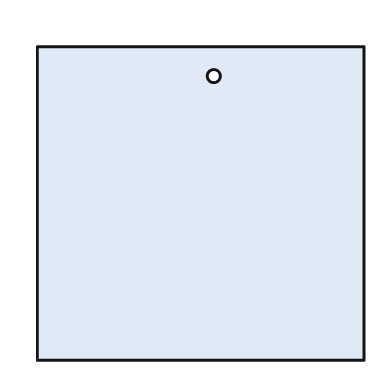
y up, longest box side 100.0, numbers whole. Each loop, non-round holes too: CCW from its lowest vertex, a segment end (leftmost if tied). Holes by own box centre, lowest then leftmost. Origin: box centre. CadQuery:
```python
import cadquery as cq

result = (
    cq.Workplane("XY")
    .moveTo(-50.0, -48.0)
    .lineTo(50.0, -48.0)
    .lineTo(50.0, 48.0)
    .lineTo(-50.0, 48.0)
    .close()
    .moveTo(4.0, 39.0)
    .circle(2.0)
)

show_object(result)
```